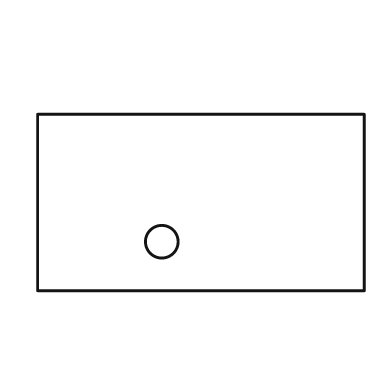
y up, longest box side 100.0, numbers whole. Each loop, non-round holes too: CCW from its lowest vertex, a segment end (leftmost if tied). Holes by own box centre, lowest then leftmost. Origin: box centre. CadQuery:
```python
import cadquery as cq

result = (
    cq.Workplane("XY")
    .moveTo(-50.0, -27.0)
    .lineTo(50.0, -27.0)
    .lineTo(50.0, 27.0)
    .lineTo(-50.0, 27.0)
    .close()
    .moveTo(-12.0, -12.0)
    .circle(5.0)
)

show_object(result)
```